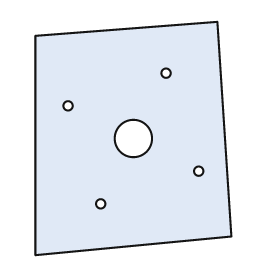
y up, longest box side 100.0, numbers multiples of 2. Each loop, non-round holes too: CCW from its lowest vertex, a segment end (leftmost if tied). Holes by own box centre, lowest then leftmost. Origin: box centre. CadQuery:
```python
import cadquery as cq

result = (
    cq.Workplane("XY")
    .moveTo(-42.0, -50.0)
    .lineTo(42.0, -42.0)
    .lineTo(36.0, 50.0)
    .lineTo(-42.0, 44.0)
    .close()
    .moveTo(-14.0, -28.0)
    .circle(2.0)
    .moveTo(28.0, -14.0)
    .circle(2.0)
    .moveTo(0.0, 0.0)
    .circle(8.0)
    .moveTo(-28.0, 14.0)
    .circle(2.0)
    .moveTo(14.0, 28.0)
    .circle(2.0)
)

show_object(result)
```